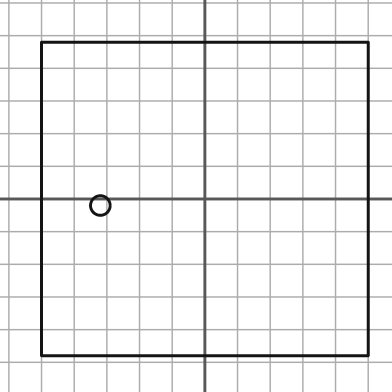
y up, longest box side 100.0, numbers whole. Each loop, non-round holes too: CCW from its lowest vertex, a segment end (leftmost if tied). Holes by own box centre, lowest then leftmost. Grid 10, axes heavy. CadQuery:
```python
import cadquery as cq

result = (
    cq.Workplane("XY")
    .moveTo(-50.0, -48.0)
    .lineTo(50.0, -48.0)
    .lineTo(50.0, 48.0)
    .lineTo(-50.0, 48.0)
    .close()
    .moveTo(-32.0, -2.0)
    .circle(3.0)
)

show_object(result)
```